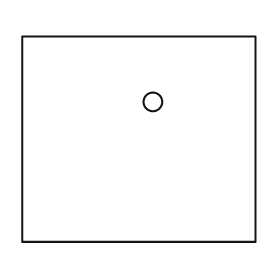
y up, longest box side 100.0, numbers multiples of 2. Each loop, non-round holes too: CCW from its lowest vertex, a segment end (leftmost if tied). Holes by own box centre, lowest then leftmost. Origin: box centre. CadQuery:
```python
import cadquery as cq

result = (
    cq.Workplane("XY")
    .moveTo(-50.0, -44.0)
    .lineTo(50.0, -44.0)
    .lineTo(50.0, 44.0)
    .lineTo(-50.0, 44.0)
    .close()
    .moveTo(6.0, 16.0)
    .circle(4.0)
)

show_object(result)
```